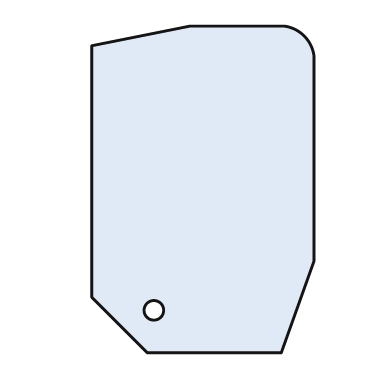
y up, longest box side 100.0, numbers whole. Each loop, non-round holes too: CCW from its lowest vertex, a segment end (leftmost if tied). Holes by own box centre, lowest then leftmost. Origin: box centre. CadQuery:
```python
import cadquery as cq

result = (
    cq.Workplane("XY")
    .moveTo(-17.0, -50.0)
    .lineTo(24.0, -50.0)
    .lineTo(34.0, -22.0)
    .lineTo(34.0, 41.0)
    .threePointArc((31.0, 47.0), (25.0, 50.0))
    .lineTo(-4.0, 50.0)
    .lineTo(-34.0, 44.0)
    .lineTo(-34.0, -33.0)
    .close()
    .moveTo(-15.0, -37.0)
    .circle(3.0)
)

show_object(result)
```